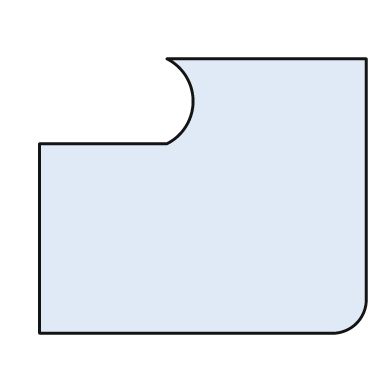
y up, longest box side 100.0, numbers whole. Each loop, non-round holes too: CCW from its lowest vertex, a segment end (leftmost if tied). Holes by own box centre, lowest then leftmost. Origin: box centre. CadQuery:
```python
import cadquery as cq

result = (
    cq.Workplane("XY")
    .moveTo(-50.0, -42.0)
    .lineTo(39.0, -42.0)
    .threePointArc((47.0, -39.0), (50.0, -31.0))
    .lineTo(50.0, 42.0)
    .lineTo(-11.0, 42.0)
    .threePointArc((-3.0, 29.0), (-11.0, 16.0))
    .lineTo(-50.0, 16.0)
    .close()
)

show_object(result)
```